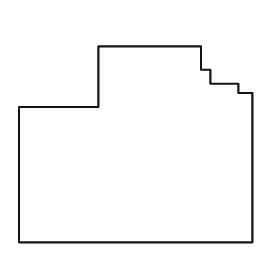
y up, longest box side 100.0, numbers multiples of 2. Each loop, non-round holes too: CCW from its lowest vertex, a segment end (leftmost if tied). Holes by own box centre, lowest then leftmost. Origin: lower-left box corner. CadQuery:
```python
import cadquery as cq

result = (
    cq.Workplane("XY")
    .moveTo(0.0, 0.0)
    .lineTo(100.0, 0.0)
    .lineTo(100.0, 64.0)
    .lineTo(94.0, 64.0)
    .lineTo(94.0, 68.0)
    .lineTo(82.0, 68.0)
    .lineTo(82.0, 74.0)
    .lineTo(78.0, 74.0)
    .lineTo(78.0, 84.0)
    .lineTo(34.0, 84.0)
    .lineTo(34.0, 58.0)
    .lineTo(0.0, 58.0)
    .close()
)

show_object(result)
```